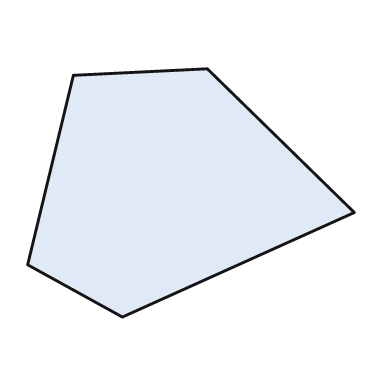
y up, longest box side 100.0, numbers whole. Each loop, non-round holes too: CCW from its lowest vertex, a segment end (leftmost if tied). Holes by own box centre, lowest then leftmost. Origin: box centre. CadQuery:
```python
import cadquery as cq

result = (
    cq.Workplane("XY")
    .moveTo(-21.0, -38.0)
    .lineTo(50.0, -6.0)
    .lineTo(5.0, 38.0)
    .lineTo(-36.0, 36.0)
    .lineTo(-50.0, -22.0)
    .close()
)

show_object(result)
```